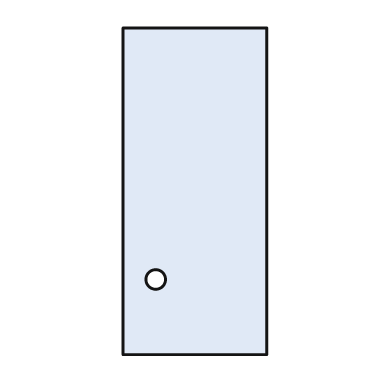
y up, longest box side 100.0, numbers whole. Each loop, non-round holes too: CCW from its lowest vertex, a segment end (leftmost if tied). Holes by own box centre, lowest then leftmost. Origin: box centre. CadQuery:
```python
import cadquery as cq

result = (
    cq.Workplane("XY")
    .moveTo(-22.0, -50.0)
    .lineTo(22.0, -50.0)
    .lineTo(22.0, 50.0)
    .lineTo(-22.0, 50.0)
    .close()
    .moveTo(-12.0, -27.0)
    .circle(3.0)
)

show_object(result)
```